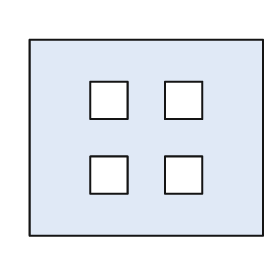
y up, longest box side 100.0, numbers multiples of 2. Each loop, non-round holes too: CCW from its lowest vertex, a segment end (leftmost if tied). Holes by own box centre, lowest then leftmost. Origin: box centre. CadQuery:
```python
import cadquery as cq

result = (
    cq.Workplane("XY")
    .moveTo(-50.0, -42.0)
    .lineTo(50.0, -42.0)
    .lineTo(50.0, 42.0)
    .lineTo(-50.0, 42.0)
    .close()
    .moveTo(-24.0, -24.0)
    .lineTo(-8.0, -24.0)
    .lineTo(-8.0, -8.0)
    .lineTo(-24.0, -8.0)
    .close()
    .moveTo(8.0, -24.0)
    .lineTo(24.0, -24.0)
    .lineTo(24.0, -8.0)
    .lineTo(8.0, -8.0)
    .close()
    .moveTo(-24.0, 8.0)
    .lineTo(-8.0, 8.0)
    .lineTo(-8.0, 24.0)
    .lineTo(-24.0, 24.0)
    .close()
    .moveTo(8.0, 8.0)
    .lineTo(24.0, 8.0)
    .lineTo(24.0, 24.0)
    .lineTo(8.0, 24.0)
    .close()
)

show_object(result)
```